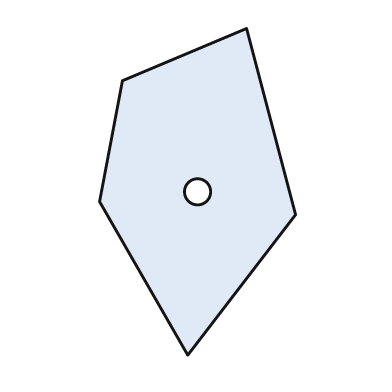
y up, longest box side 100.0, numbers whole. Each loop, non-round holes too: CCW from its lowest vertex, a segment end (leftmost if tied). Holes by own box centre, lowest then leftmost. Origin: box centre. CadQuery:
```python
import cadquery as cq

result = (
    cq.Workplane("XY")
    .moveTo(-3.0, -50.0)
    .lineTo(30.0, -7.0)
    .lineTo(15.0, 50.0)
    .lineTo(-23.0, 34.0)
    .lineTo(-30.0, -3.0)
    .close()
    .moveTo(0.0, 0.0)
    .circle(4.0)
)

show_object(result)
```